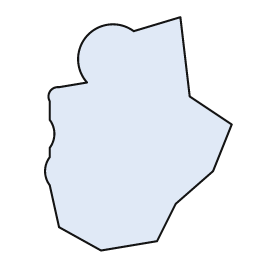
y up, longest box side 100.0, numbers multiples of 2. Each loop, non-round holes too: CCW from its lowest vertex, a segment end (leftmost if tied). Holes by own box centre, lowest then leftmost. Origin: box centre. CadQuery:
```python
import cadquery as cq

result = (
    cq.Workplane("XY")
    .moveTo(-16.0, -50.0)
    .lineTo(8.0, -46.0)
    .lineTo(16.0, -30.0)
    .lineTo(32.0, -16.0)
    .lineTo(40.0, 4.0)
    .lineTo(22.0, 16.0)
    .lineTo(18.0, 50.0)
    .lineTo(-2.0, 44.0)
    .threePointArc((-22.0, 42.0), (-22.0, 22.0))
    .lineTo(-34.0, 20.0)
    .threePointArc((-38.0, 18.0), (-38.0, 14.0))
    .lineTo(-38.0, 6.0)
    .threePointArc((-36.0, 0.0), (-38.0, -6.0))
    .lineTo(-38.0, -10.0)
    .threePointArc((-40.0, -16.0), (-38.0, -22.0))
    .lineTo(-34.0, -40.0)
    .close()
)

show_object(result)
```